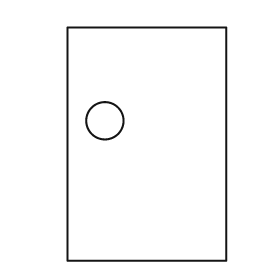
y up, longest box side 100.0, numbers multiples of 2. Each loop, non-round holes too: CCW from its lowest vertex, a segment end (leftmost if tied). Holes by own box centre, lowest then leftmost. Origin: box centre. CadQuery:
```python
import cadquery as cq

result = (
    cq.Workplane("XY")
    .moveTo(-34.0, -50.0)
    .lineTo(34.0, -50.0)
    .lineTo(34.0, 50.0)
    .lineTo(-34.0, 50.0)
    .close()
    .moveTo(-18.0, 10.0)
    .circle(8.0)
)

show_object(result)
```